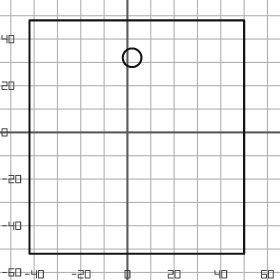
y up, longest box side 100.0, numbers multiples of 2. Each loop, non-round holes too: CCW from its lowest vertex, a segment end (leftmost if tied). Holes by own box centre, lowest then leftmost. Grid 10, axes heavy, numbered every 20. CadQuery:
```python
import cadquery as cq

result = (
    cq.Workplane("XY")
    .moveTo(-42.0, -52.0)
    .lineTo(50.0, -52.0)
    .lineTo(50.0, 48.0)
    .lineTo(-42.0, 48.0)
    .close()
    .moveTo(2.0, 32.0)
    .circle(4.0)
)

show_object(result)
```